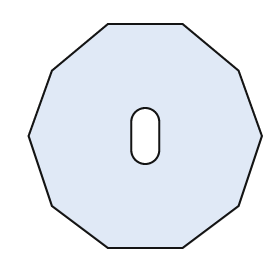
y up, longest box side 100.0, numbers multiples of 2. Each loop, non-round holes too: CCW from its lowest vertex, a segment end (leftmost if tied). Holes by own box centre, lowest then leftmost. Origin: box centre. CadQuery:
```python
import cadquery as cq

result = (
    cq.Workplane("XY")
    .moveTo(-16.0, -48.0)
    .lineTo(16.0, -48.0)
    .lineTo(40.0, -30.0)
    .lineTo(50.0, 0.0)
    .lineTo(40.0, 28.0)
    .lineTo(16.0, 48.0)
    .lineTo(-16.0, 48.0)
    .lineTo(-40.0, 28.0)
    .lineTo(-50.0, 0.0)
    .lineTo(-40.0, -30.0)
    .close()
    .moveTo(-6.0, -6.0)
    .threePointArc((0.0, -12.0), (6.0, -6.0))
    .lineTo(6.0, 6.0)
    .threePointArc((0.0, 12.0), (-6.0, 6.0))
    .close()
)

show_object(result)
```